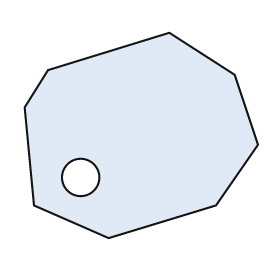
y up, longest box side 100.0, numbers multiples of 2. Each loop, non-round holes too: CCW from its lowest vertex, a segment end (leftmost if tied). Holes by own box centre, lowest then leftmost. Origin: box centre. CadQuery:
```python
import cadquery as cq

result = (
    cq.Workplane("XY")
    .moveTo(-14.0, -44.0)
    .lineTo(32.0, -30.0)
    .lineTo(50.0, -4.0)
    .lineTo(40.0, 26.0)
    .lineTo(12.0, 44.0)
    .lineTo(-40.0, 28.0)
    .lineTo(-50.0, 12.0)
    .lineTo(-46.0, -30.0)
    .close()
    .moveTo(-26.0, -18.0)
    .circle(8.0)
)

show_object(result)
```